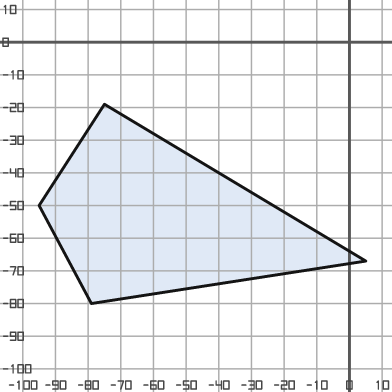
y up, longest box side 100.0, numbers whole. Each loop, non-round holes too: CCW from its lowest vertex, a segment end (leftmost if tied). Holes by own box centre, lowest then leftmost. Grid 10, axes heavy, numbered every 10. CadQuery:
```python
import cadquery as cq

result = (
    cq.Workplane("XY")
    .moveTo(-79.0, -80.0)
    .lineTo(5.0, -67.0)
    .lineTo(-75.0, -19.0)
    .lineTo(-95.0, -50.0)
    .close()
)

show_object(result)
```